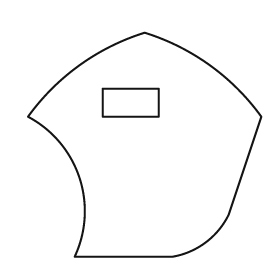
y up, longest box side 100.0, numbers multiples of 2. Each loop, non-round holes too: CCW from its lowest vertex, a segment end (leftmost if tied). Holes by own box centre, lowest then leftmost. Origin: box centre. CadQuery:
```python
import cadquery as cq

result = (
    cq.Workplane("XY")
    .moveTo(-30.0, -48.0)
    .lineTo(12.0, -48.0)
    .threePointArc((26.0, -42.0), (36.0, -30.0))
    .lineTo(50.0, 12.0)
    .threePointArc((28.0, 34.0), (0.0, 48.0))
    .threePointArc((-28.0, 34.0), (-50.0, 12.0))
    .threePointArc((-28.0, -14.0), (-30.0, -48.0))
    .close()
    .moveTo(-18.0, 12.0)
    .lineTo(6.0, 12.0)
    .lineTo(6.0, 24.0)
    .lineTo(-18.0, 24.0)
    .close()
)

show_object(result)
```